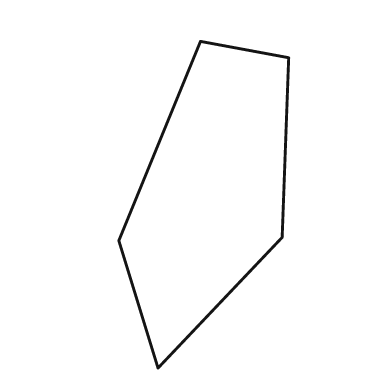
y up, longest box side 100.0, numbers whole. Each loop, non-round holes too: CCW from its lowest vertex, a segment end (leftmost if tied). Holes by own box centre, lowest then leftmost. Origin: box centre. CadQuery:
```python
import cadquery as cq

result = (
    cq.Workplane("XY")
    .moveTo(-14.0, -50.0)
    .lineTo(24.0, -10.0)
    .lineTo(26.0, 45.0)
    .lineTo(-1.0, 50.0)
    .lineTo(-26.0, -11.0)
    .close()
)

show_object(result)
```